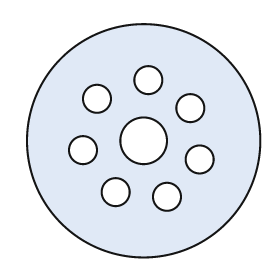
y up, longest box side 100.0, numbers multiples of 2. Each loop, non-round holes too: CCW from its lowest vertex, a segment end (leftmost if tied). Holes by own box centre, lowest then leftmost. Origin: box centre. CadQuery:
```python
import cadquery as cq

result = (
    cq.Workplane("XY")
    .moveTo(0.0, 0.0)
    .circle(50.0)
    .moveTo(10.0, -24.0)
    .circle(6.0)
    .moveTo(-12.0, -22.0)
    .circle(6.0)
    .moveTo(24.0, -8.0)
    .circle(6.0)
    .moveTo(-26.0, -4.0)
    .circle(6.0)
    .moveTo(0.0, 0.0)
    .circle(10.0)
    .moveTo(20.0, 14.0)
    .circle(6.0)
    .moveTo(-20.0, 18.0)
    .circle(6.0)
    .moveTo(2.0, 26.0)
    .circle(6.0)
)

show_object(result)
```